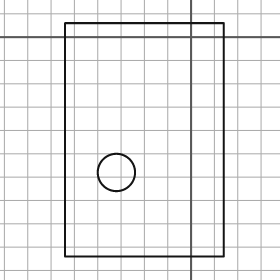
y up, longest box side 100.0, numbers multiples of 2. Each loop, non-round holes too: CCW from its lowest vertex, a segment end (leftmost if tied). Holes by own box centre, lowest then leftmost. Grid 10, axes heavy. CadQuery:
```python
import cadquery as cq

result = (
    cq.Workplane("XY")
    .moveTo(-54.0, -94.0)
    .lineTo(14.0, -94.0)
    .lineTo(14.0, 6.0)
    .lineTo(-54.0, 6.0)
    .close()
    .moveTo(-32.0, -58.0)
    .circle(8.0)
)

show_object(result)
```